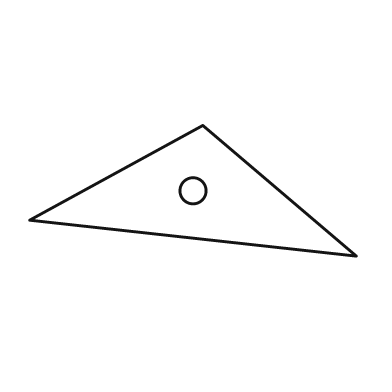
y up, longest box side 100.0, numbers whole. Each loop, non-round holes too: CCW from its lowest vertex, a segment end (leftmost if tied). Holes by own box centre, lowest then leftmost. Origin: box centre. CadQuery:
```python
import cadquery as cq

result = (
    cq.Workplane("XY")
    .moveTo(50.0, -20.0)
    .lineTo(3.0, 20.0)
    .lineTo(-50.0, -9.0)
    .close()
    .moveTo(0.0, 0.0)
    .circle(4.0)
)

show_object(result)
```